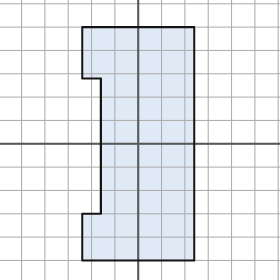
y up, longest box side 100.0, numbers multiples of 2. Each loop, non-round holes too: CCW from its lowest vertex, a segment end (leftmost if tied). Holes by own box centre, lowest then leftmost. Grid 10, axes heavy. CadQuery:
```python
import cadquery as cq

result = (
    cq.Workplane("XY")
    .moveTo(-24.0, -50.0)
    .lineTo(24.0, -50.0)
    .lineTo(24.0, 50.0)
    .lineTo(-24.0, 50.0)
    .lineTo(-24.0, 28.0)
    .lineTo(-16.0, 28.0)
    .lineTo(-16.0, -30.0)
    .lineTo(-24.0, -30.0)
    .close()
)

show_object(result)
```